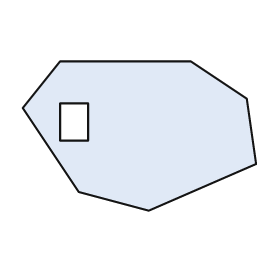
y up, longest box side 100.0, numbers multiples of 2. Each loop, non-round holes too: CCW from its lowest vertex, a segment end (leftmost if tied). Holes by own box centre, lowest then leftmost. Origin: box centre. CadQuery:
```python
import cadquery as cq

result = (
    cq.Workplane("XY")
    .moveTo(4.0, -32.0)
    .lineTo(50.0, -12.0)
    .lineTo(46.0, 16.0)
    .lineTo(22.0, 32.0)
    .lineTo(-34.0, 32.0)
    .lineTo(-50.0, 12.0)
    .lineTo(-26.0, -24.0)
    .close()
    .moveTo(-34.0, -2.0)
    .lineTo(-22.0, -2.0)
    .lineTo(-22.0, 14.0)
    .lineTo(-34.0, 14.0)
    .close()
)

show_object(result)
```